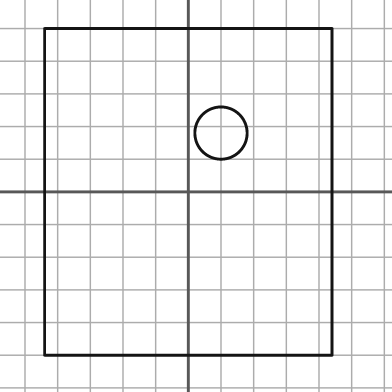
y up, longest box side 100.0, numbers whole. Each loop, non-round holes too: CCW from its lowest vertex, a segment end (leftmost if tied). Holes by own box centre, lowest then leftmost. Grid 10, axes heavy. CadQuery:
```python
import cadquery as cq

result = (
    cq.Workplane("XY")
    .moveTo(-44.0, -50.0)
    .lineTo(44.0, -50.0)
    .lineTo(44.0, 50.0)
    .lineTo(-44.0, 50.0)
    .close()
    .moveTo(10.0, 18.0)
    .circle(8.0)
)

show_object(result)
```